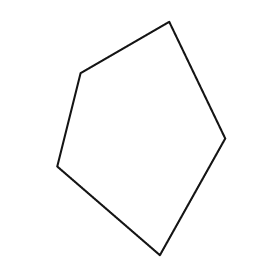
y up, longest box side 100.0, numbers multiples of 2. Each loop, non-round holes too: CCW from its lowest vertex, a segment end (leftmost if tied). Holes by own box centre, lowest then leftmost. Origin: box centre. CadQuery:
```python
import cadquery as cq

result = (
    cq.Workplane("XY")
    .moveTo(8.0, -50.0)
    .lineTo(36.0, 0.0)
    .lineTo(12.0, 50.0)
    .lineTo(-26.0, 28.0)
    .lineTo(-36.0, -12.0)
    .close()
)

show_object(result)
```